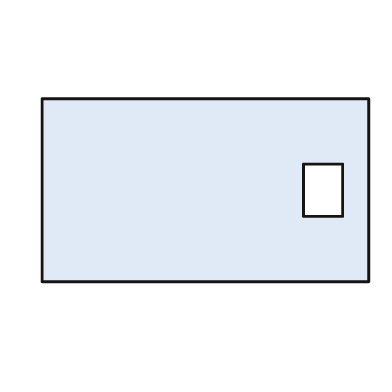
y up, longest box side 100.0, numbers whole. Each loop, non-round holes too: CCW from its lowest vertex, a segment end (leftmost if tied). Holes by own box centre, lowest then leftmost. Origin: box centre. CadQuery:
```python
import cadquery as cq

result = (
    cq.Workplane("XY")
    .moveTo(-50.0, -28.0)
    .lineTo(50.0, -28.0)
    .lineTo(50.0, 28.0)
    .lineTo(-50.0, 28.0)
    .close()
    .moveTo(30.0, -8.0)
    .lineTo(42.0, -8.0)
    .lineTo(42.0, 8.0)
    .lineTo(30.0, 8.0)
    .close()
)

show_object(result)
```